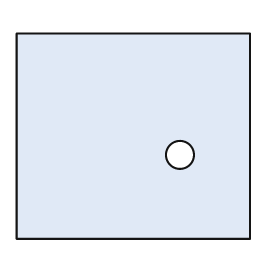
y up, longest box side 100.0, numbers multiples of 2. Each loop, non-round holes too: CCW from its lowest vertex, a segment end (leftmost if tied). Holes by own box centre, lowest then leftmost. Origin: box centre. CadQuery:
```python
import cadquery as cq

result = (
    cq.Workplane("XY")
    .moveTo(-50.0, -44.0)
    .lineTo(50.0, -44.0)
    .lineTo(50.0, 44.0)
    .lineTo(-50.0, 44.0)
    .close()
    .moveTo(20.0, -8.0)
    .circle(6.0)
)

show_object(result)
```